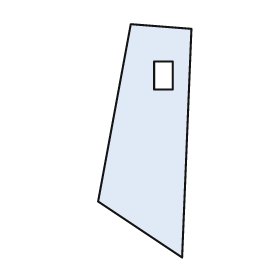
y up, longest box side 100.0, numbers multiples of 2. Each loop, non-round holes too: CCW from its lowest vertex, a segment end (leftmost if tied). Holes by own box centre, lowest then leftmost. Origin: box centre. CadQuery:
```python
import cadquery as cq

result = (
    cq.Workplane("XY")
    .moveTo(16.0, -50.0)
    .lineTo(20.0, 48.0)
    .lineTo(-6.0, 50.0)
    .lineTo(-20.0, -26.0)
    .close()
    .moveTo(4.0, 22.0)
    .lineTo(12.0, 22.0)
    .lineTo(12.0, 34.0)
    .lineTo(4.0, 34.0)
    .close()
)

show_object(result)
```